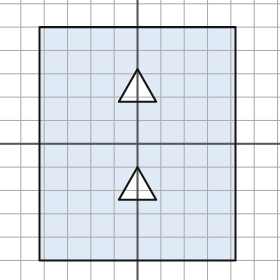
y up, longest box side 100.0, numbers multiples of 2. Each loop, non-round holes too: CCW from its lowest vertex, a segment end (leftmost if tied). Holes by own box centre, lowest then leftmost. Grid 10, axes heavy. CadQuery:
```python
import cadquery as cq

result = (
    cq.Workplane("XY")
    .moveTo(-42.0, -50.0)
    .lineTo(42.0, -50.0)
    .lineTo(42.0, 50.0)
    .lineTo(-42.0, 50.0)
    .close()
    .moveTo(-8.0, -24.0)
    .lineTo(8.0, -24.0)
    .lineTo(0.0, -10.0)
    .close()
    .moveTo(-8.0, 18.0)
    .lineTo(8.0, 18.0)
    .lineTo(0.0, 32.0)
    .close()
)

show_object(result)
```